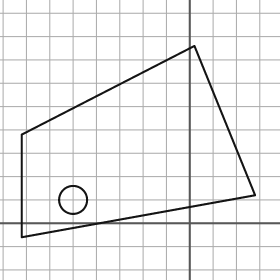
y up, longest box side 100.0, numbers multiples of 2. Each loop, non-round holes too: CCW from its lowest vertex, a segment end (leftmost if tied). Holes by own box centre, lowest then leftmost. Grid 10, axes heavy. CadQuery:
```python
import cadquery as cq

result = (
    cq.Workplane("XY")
    .moveTo(-72.0, -6.0)
    .lineTo(28.0, 12.0)
    .lineTo(2.0, 76.0)
    .lineTo(-72.0, 38.0)
    .close()
    .moveTo(-50.0, 10.0)
    .circle(6.0)
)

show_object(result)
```